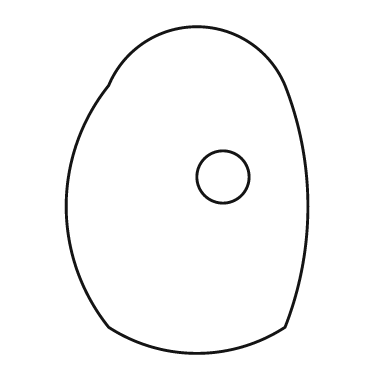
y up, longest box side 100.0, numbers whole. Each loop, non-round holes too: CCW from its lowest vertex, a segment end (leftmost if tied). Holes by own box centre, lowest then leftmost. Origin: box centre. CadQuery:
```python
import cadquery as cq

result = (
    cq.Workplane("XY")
    .moveTo(-24.0, -42.0)
    .threePointArc((3.0, -50.0), (30.0, -42.0))
    .threePointArc((37.0, -5.0), (30.0, 32.0))
    .threePointArc((3.0, 50.0), (-24.0, 32.0))
    .threePointArc((-37.0, -5.0), (-24.0, -42.0))
    .close()
    .moveTo(11.0, 4.0)
    .circle(8.0)
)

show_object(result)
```